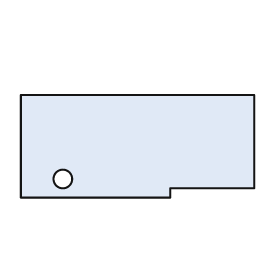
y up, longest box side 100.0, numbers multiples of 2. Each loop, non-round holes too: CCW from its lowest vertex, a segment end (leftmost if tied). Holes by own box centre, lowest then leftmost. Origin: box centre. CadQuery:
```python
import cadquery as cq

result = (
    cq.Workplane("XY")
    .moveTo(-50.0, -22.0)
    .lineTo(14.0, -22.0)
    .lineTo(14.0, -18.0)
    .lineTo(50.0, -18.0)
    .lineTo(50.0, 22.0)
    .lineTo(-50.0, 22.0)
    .close()
    .moveTo(-32.0, -14.0)
    .circle(4.0)
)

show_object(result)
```